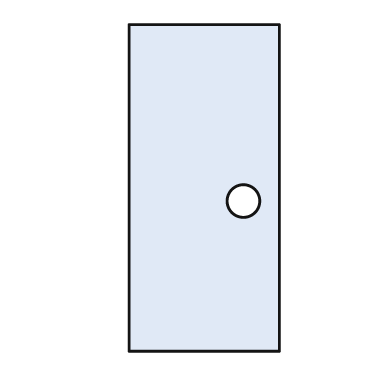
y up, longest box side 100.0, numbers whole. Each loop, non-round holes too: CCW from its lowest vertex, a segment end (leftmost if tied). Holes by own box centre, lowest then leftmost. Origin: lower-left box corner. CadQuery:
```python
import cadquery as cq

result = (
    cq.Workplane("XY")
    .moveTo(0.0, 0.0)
    .lineTo(46.0, 0.0)
    .lineTo(46.0, 100.0)
    .lineTo(0.0, 100.0)
    .close()
    .moveTo(35.0, 46.0)
    .circle(5.0)
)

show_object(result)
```